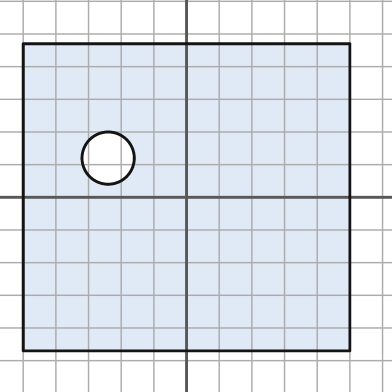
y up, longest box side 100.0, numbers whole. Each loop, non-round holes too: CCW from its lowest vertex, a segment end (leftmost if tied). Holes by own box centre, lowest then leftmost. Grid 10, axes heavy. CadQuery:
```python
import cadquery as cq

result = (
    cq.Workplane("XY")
    .moveTo(-50.0, -47.0)
    .lineTo(50.0, -47.0)
    .lineTo(50.0, 47.0)
    .lineTo(-50.0, 47.0)
    .close()
    .moveTo(-24.0, 12.0)
    .circle(8.0)
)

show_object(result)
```